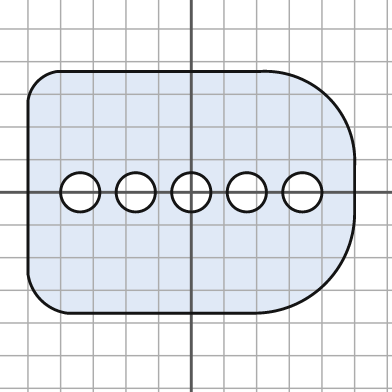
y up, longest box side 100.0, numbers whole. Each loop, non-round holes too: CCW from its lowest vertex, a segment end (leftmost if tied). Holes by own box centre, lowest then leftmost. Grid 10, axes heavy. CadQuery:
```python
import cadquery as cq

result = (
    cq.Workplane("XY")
    .moveTo(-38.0, -37.0)
    .lineTo(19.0, -37.0)
    .threePointArc((41.0, -28.0), (50.0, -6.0))
    .lineTo(50.0, 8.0)
    .threePointArc((42.0, 29.0), (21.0, 37.0))
    .lineTo(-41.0, 37.0)
    .threePointArc((-47.0, 34.0), (-50.0, 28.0))
    .lineTo(-50.0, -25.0)
    .threePointArc((-46.0, -33.0), (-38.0, -37.0))
    .close()
    .moveTo(-34.0, 0.0)
    .circle(6.0)
    .moveTo(-17.0, 0.0)
    .circle(6.0)
    .moveTo(0.0, 0.0)
    .circle(6.0)
    .moveTo(17.0, 0.0)
    .circle(6.0)
    .moveTo(34.0, 0.0)
    .circle(6.0)
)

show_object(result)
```